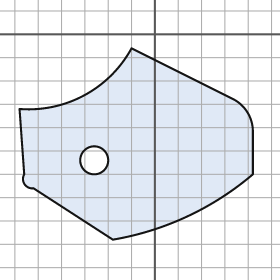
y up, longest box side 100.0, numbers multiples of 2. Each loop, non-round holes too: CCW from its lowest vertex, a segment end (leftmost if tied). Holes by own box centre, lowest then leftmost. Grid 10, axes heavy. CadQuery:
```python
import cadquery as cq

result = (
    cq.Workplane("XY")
    .moveTo(-18.0, -88.0)
    .threePointArc((14.0, -78.0), (42.0, -60.0))
    .lineTo(42.0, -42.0)
    .threePointArc((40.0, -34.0), (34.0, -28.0))
    .lineTo(-10.0, -6.0)
    .threePointArc((-30.0, -26.0), (-58.0, -32.0))
    .lineTo(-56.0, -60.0)
    .threePointArc((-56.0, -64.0), (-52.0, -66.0))
    .close()
    .moveTo(-26.0, -54.0)
    .circle(6.0)
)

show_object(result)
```